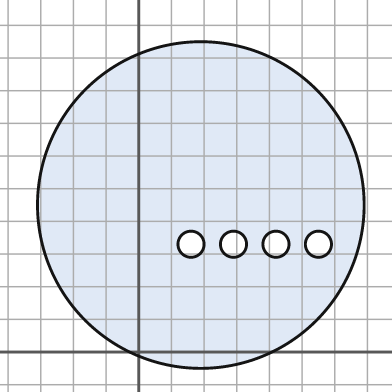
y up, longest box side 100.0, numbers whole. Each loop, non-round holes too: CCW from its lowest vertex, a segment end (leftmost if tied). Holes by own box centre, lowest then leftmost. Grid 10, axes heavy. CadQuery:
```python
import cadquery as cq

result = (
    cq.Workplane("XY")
    .moveTo(19.0, 45.0)
    .circle(50.0)
    .moveTo(16.0, 33.0)
    .circle(4.0)
    .moveTo(29.0, 33.0)
    .circle(4.0)
    .moveTo(42.0, 33.0)
    .circle(4.0)
    .moveTo(55.0, 33.0)
    .circle(4.0)
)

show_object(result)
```